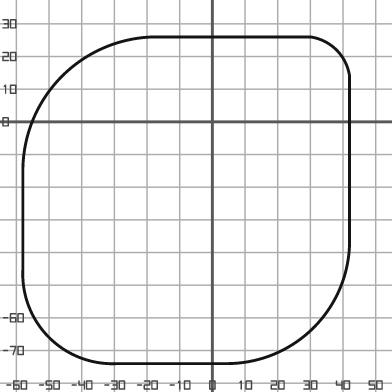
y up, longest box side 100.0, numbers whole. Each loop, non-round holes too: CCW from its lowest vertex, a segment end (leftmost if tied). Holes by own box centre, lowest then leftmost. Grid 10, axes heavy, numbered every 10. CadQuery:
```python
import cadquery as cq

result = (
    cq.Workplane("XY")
    .moveTo(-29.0, -74.0)
    .lineTo(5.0, -74.0)
    .threePointArc((31.0, -63.0), (42.0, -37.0))
    .lineTo(42.0, 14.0)
    .threePointArc((38.0, 22.0), (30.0, 26.0))
    .lineTo(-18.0, 26.0)
    .threePointArc((-46.0, 14.0), (-58.0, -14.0))
    .lineTo(-58.0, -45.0)
    .threePointArc((-50.0, -66.0), (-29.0, -74.0))
    .close()
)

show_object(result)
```